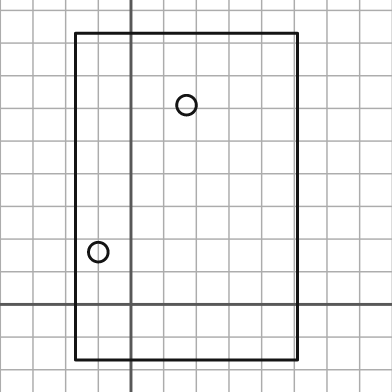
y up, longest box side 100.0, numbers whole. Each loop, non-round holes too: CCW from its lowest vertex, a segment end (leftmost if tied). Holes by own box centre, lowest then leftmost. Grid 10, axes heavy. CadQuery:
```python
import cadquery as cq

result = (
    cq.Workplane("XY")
    .moveTo(-17.0, -17.0)
    .lineTo(51.0, -17.0)
    .lineTo(51.0, 83.0)
    .lineTo(-17.0, 83.0)
    .close()
    .moveTo(-10.0, 16.0)
    .circle(3.0)
    .moveTo(17.0, 61.0)
    .circle(3.0)
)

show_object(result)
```